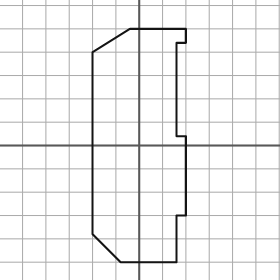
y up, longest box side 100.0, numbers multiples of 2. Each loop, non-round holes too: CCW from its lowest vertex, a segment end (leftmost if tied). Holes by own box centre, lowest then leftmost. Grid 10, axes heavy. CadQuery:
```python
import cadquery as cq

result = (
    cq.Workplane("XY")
    .moveTo(-8.0, -50.0)
    .lineTo(16.0, -50.0)
    .lineTo(16.0, -30.0)
    .lineTo(20.0, -30.0)
    .lineTo(20.0, 4.0)
    .lineTo(16.0, 4.0)
    .lineTo(16.0, 44.0)
    .lineTo(20.0, 44.0)
    .lineTo(20.0, 50.0)
    .lineTo(-4.0, 50.0)
    .lineTo(-20.0, 40.0)
    .lineTo(-20.0, -38.0)
    .close()
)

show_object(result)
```